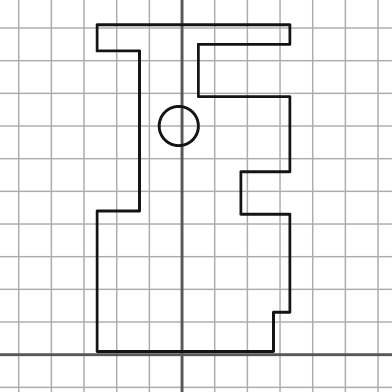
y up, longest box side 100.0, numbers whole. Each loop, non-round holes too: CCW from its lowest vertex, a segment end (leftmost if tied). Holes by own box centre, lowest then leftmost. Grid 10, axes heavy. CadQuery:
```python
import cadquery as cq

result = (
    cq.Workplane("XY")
    .moveTo(-26.0, 1.0)
    .lineTo(28.0, 1.0)
    .lineTo(28.0, 13.0)
    .lineTo(33.0, 13.0)
    .lineTo(33.0, 43.0)
    .lineTo(18.0, 43.0)
    .lineTo(18.0, 56.0)
    .lineTo(33.0, 56.0)
    .lineTo(33.0, 79.0)
    .lineTo(5.0, 79.0)
    .lineTo(5.0, 95.0)
    .lineTo(33.0, 95.0)
    .lineTo(33.0, 101.0)
    .lineTo(-26.0, 101.0)
    .lineTo(-26.0, 93.0)
    .lineTo(-13.0, 93.0)
    .lineTo(-13.0, 44.0)
    .lineTo(-26.0, 44.0)
    .close()
    .moveTo(-1.0, 70.0)
    .circle(6.0)
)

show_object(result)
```